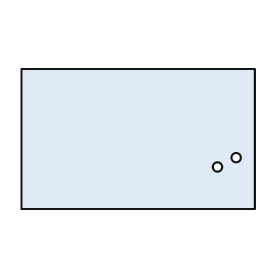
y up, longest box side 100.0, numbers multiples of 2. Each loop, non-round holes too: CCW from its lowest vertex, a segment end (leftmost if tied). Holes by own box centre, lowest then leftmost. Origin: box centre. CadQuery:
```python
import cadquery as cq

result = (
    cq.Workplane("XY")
    .moveTo(-50.0, -30.0)
    .lineTo(50.0, -30.0)
    .lineTo(50.0, 30.0)
    .lineTo(-50.0, 30.0)
    .close()
    .moveTo(34.0, -12.0)
    .circle(2.0)
    .moveTo(42.0, -8.0)
    .circle(2.0)
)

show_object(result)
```